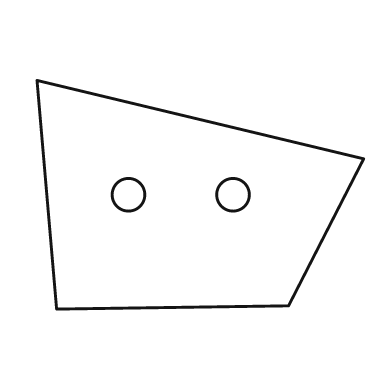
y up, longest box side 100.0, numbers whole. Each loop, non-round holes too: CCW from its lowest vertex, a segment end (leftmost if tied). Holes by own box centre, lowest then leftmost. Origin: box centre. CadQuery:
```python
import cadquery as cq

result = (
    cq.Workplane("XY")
    .moveTo(-44.0, -35.0)
    .lineTo(27.0, -34.0)
    .lineTo(50.0, 11.0)
    .lineTo(-50.0, 35.0)
    .close()
    .moveTo(-22.0, 0.0)
    .circle(5.0)
    .moveTo(10.0, 0.0)
    .circle(5.0)
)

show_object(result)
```